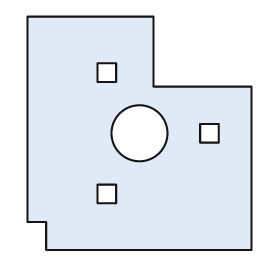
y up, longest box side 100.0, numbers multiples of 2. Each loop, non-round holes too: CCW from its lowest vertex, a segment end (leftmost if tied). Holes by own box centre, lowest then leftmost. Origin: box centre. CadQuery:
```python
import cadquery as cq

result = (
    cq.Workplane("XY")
    .moveTo(-40.0, -50.0)
    .lineTo(48.0, -50.0)
    .lineTo(48.0, 20.0)
    .lineTo(6.0, 20.0)
    .lineTo(6.0, 50.0)
    .lineTo(-48.0, 50.0)
    .lineTo(-48.0, -38.0)
    .lineTo(-40.0, -38.0)
    .close()
    .moveTo(-18.0, -30.0)
    .lineTo(-10.0, -30.0)
    .lineTo(-10.0, -22.0)
    .lineTo(-18.0, -22.0)
    .close()
    .moveTo(0.0, 0.0)
    .circle(12.0)
    .moveTo(26.0, -4.0)
    .lineTo(34.0, -4.0)
    .lineTo(34.0, 4.0)
    .lineTo(26.0, 4.0)
    .close()
    .moveTo(-18.0, 22.0)
    .lineTo(-10.0, 22.0)
    .lineTo(-10.0, 30.0)
    .lineTo(-18.0, 30.0)
    .close()
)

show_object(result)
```